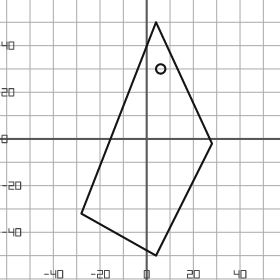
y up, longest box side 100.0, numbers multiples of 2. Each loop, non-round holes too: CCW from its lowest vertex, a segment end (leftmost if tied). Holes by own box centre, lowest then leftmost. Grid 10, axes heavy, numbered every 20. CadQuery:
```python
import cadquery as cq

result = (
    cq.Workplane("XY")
    .moveTo(4.0, -50.0)
    .lineTo(28.0, -2.0)
    .lineTo(4.0, 50.0)
    .lineTo(-28.0, -32.0)
    .close()
    .moveTo(6.0, 30.0)
    .circle(2.0)
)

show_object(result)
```